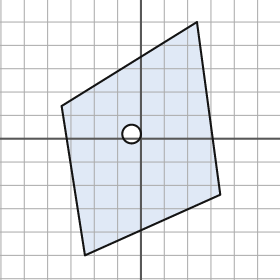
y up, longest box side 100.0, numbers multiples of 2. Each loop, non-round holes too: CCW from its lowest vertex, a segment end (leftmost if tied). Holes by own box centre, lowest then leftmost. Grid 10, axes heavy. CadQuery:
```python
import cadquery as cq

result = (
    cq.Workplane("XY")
    .moveTo(-24.0, -50.0)
    .lineTo(34.0, -24.0)
    .lineTo(24.0, 50.0)
    .lineTo(-34.0, 14.0)
    .close()
    .moveTo(-4.0, 2.0)
    .circle(4.0)
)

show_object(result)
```